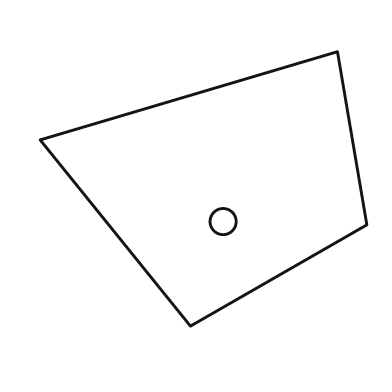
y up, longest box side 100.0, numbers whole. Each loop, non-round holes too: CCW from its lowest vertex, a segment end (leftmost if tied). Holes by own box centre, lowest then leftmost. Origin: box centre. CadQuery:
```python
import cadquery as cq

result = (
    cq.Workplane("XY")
    .moveTo(-4.0, -42.0)
    .lineTo(50.0, -11.0)
    .lineTo(41.0, 42.0)
    .lineTo(-50.0, 15.0)
    .close()
    .moveTo(6.0, -10.0)
    .circle(4.0)
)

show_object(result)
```